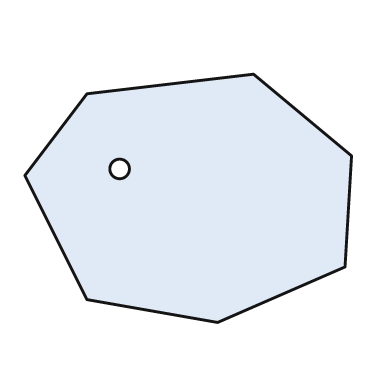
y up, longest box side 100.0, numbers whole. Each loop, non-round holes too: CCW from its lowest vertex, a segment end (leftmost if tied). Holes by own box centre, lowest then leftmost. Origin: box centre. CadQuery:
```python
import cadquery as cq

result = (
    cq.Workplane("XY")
    .moveTo(9.0, -38.0)
    .lineTo(48.0, -21.0)
    .lineTo(50.0, 13.0)
    .lineTo(20.0, 38.0)
    .lineTo(-31.0, 32.0)
    .lineTo(-50.0, 7.0)
    .lineTo(-31.0, -31.0)
    .close()
    .moveTo(-21.0, 9.0)
    .circle(3.0)
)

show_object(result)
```